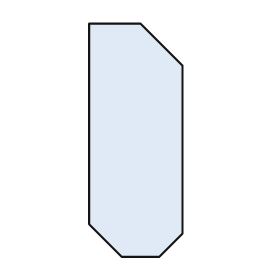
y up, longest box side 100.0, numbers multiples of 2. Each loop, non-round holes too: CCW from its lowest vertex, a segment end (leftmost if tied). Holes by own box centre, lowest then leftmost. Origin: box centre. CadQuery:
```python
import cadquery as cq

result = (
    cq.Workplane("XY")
    .moveTo(-6.0, -50.0)
    .lineTo(10.0, -50.0)
    .lineTo(20.0, -40.0)
    .lineTo(20.0, 32.0)
    .lineTo(2.0, 50.0)
    .lineTo(-20.0, 50.0)
    .lineTo(-20.0, -36.0)
    .close()
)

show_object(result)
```